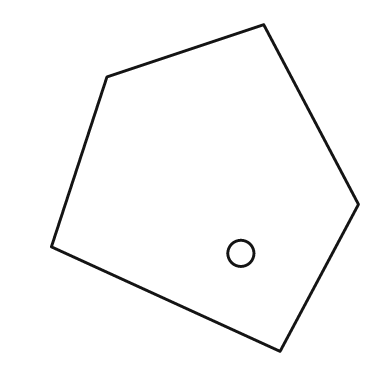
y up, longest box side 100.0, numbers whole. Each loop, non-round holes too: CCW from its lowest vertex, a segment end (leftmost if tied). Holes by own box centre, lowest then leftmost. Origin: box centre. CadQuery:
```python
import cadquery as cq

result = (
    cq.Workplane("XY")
    .moveTo(23.0, -50.0)
    .lineTo(47.0, -5.0)
    .lineTo(18.0, 50.0)
    .lineTo(-30.0, 34.0)
    .lineTo(-47.0, -18.0)
    .close()
    .moveTo(11.0, -20.0)
    .circle(4.0)
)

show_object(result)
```